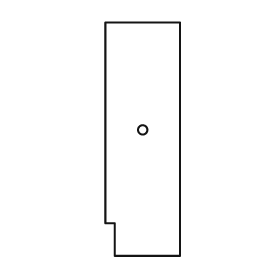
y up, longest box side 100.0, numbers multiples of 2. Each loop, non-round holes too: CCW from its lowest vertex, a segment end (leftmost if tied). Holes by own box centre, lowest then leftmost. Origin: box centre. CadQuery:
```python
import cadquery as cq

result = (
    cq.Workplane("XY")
    .moveTo(-12.0, -50.0)
    .lineTo(16.0, -50.0)
    .lineTo(16.0, 50.0)
    .lineTo(-16.0, 50.0)
    .lineTo(-16.0, -36.0)
    .lineTo(-12.0, -36.0)
    .close()
    .moveTo(0.0, 4.0)
    .circle(2.0)
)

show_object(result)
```